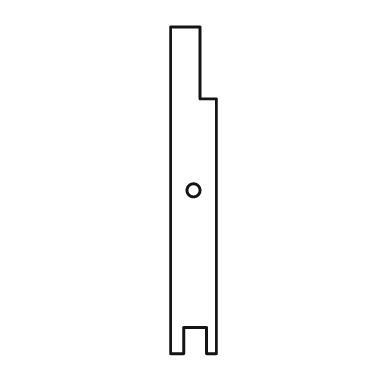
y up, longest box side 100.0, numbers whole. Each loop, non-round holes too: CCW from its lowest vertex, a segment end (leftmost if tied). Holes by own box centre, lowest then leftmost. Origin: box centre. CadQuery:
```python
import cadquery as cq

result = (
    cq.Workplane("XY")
    .moveTo(-7.0, -50.0)
    .lineTo(-3.0, -50.0)
    .lineTo(-3.0, -42.0)
    .lineTo(4.0, -42.0)
    .lineTo(4.0, -50.0)
    .lineTo(7.0, -50.0)
    .lineTo(7.0, 28.0)
    .lineTo(2.0, 28.0)
    .lineTo(2.0, 50.0)
    .lineTo(-7.0, 50.0)
    .close()
    .moveTo(0.0, 0.0)
    .circle(2.0)
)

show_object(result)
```